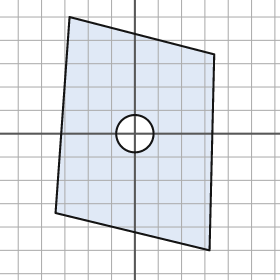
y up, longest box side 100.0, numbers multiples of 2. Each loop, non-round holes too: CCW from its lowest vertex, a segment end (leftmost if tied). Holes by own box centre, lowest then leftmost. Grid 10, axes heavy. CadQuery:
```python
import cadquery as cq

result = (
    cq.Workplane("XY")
    .moveTo(32.0, -50.0)
    .lineTo(34.0, 34.0)
    .lineTo(-28.0, 50.0)
    .lineTo(-34.0, -34.0)
    .close()
    .moveTo(0.0, 0.0)
    .circle(8.0)
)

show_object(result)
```